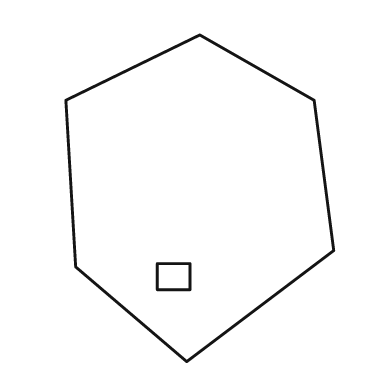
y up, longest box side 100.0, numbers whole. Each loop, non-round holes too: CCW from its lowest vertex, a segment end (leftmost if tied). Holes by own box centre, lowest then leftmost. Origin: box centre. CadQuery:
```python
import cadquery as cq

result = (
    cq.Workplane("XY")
    .moveTo(-4.0, -50.0)
    .lineTo(41.0, -16.0)
    .lineTo(35.0, 30.0)
    .lineTo(0.0, 50.0)
    .lineTo(-41.0, 30.0)
    .lineTo(-38.0, -21.0)
    .close()
    .moveTo(-13.0, -28.0)
    .lineTo(-3.0, -28.0)
    .lineTo(-3.0, -20.0)
    .lineTo(-13.0, -20.0)
    .close()
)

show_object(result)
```